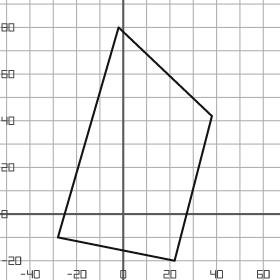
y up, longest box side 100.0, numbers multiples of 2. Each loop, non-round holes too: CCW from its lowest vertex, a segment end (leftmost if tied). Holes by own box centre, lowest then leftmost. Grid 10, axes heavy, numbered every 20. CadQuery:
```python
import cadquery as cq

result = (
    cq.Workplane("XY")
    .moveTo(22.0, -20.0)
    .lineTo(38.0, 42.0)
    .lineTo(-2.0, 80.0)
    .lineTo(-28.0, -10.0)
    .close()
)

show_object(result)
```